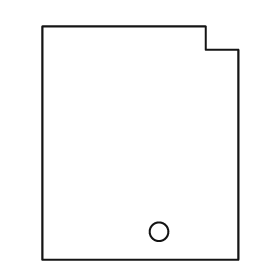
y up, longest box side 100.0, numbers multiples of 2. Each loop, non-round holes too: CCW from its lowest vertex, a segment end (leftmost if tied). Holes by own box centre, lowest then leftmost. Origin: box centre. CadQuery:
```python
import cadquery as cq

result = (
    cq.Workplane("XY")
    .moveTo(-42.0, -50.0)
    .lineTo(42.0, -50.0)
    .lineTo(42.0, 40.0)
    .lineTo(28.0, 40.0)
    .lineTo(28.0, 50.0)
    .lineTo(-42.0, 50.0)
    .close()
    .moveTo(8.0, -38.0)
    .circle(4.0)
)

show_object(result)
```